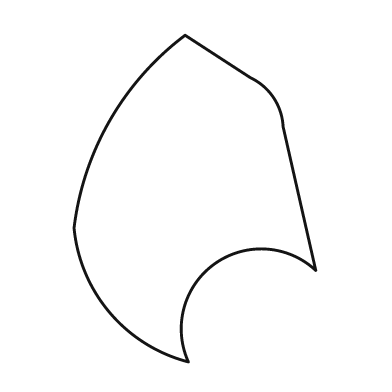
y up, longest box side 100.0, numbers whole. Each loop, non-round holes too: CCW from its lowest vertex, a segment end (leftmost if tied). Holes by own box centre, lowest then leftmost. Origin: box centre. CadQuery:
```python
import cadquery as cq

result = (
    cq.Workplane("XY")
    .moveTo(-2.0, -50.0)
    .threePointArc((6.0, -20.0), (37.0, -22.0))
    .lineTo(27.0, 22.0)
    .threePointArc((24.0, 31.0), (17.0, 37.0))
    .lineTo(-3.0, 50.0)
    .threePointArc((-26.0, 24.0), (-37.0, -9.0))
    .threePointArc((-26.0, -35.0), (-2.0, -50.0))
    .close()
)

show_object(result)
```